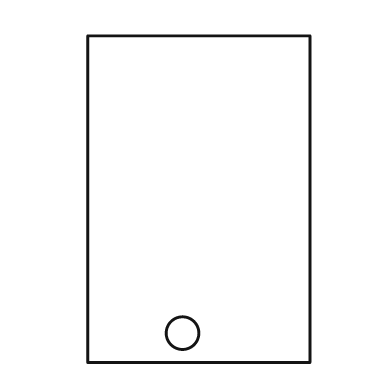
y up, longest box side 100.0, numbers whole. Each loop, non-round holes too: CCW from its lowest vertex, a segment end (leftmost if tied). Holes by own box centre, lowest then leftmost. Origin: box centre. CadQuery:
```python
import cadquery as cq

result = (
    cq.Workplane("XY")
    .moveTo(-34.0, -50.0)
    .lineTo(34.0, -50.0)
    .lineTo(34.0, 50.0)
    .lineTo(-34.0, 50.0)
    .close()
    .moveTo(-5.0, -41.0)
    .circle(5.0)
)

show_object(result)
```